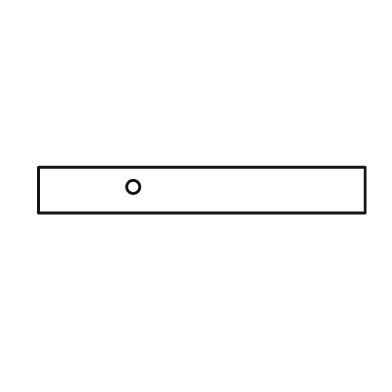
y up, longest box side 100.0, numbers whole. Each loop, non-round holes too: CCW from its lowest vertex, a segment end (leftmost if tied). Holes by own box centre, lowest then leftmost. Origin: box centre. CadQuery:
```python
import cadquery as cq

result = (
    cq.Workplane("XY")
    .moveTo(-50.0, -7.0)
    .lineTo(50.0, -7.0)
    .lineTo(50.0, 7.0)
    .lineTo(-50.0, 7.0)
    .close()
    .moveTo(-21.0, 1.0)
    .circle(2.0)
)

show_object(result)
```